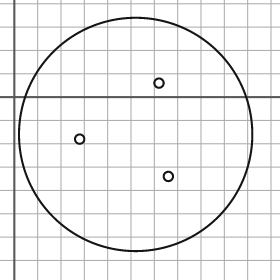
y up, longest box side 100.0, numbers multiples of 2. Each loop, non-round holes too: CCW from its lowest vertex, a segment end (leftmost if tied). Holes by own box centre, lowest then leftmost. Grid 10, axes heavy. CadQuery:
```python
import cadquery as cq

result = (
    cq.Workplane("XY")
    .moveTo(52.0, -16.0)
    .circle(50.0)
    .moveTo(66.0, -34.0)
    .circle(2.0)
    .moveTo(28.0, -18.0)
    .circle(2.0)
    .moveTo(62.0, 6.0)
    .circle(2.0)
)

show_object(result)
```